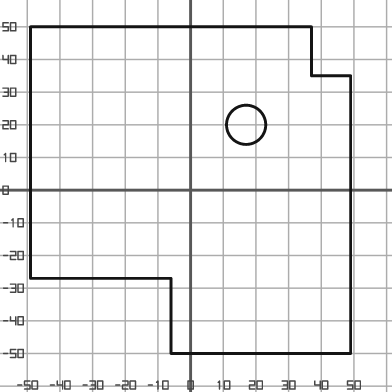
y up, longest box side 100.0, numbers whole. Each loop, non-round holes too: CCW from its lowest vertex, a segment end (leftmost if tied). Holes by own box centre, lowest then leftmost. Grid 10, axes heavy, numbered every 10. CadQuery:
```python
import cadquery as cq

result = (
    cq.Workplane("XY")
    .moveTo(-6.0, -50.0)
    .lineTo(49.0, -50.0)
    .lineTo(49.0, 35.0)
    .lineTo(37.0, 35.0)
    .lineTo(37.0, 50.0)
    .lineTo(-49.0, 50.0)
    .lineTo(-49.0, -27.0)
    .lineTo(-6.0, -27.0)
    .close()
    .moveTo(17.0, 20.0)
    .circle(6.0)
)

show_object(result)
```